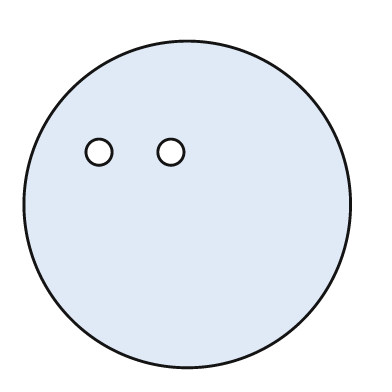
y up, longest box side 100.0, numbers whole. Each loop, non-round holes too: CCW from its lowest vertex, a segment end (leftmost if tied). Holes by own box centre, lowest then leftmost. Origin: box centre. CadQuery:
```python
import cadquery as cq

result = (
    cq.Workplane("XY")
    .moveTo(0.0, 0.0)
    .circle(50.0)
    .moveTo(-27.0, 16.0)
    .circle(4.0)
    .moveTo(-5.0, 16.0)
    .circle(4.0)
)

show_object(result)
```